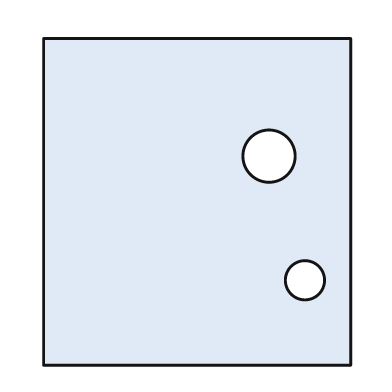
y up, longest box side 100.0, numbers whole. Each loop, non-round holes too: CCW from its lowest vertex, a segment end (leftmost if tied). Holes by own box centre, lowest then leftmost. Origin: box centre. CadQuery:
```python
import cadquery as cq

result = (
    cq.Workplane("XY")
    .moveTo(-47.0, -50.0)
    .lineTo(47.0, -50.0)
    .lineTo(47.0, 50.0)
    .lineTo(-47.0, 50.0)
    .close()
    .moveTo(33.0, -24.0)
    .circle(6.0)
    .moveTo(22.0, 14.0)
    .circle(8.0)
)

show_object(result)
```